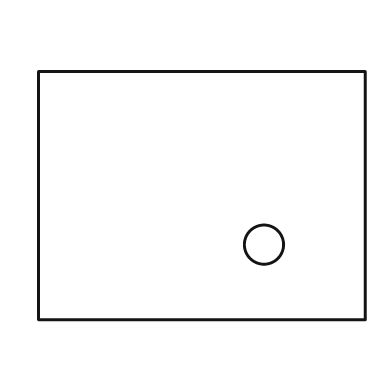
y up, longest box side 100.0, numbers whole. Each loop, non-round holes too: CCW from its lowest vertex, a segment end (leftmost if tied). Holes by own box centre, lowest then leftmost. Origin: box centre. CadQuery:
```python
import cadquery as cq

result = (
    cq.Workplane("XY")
    .moveTo(-50.0, -38.0)
    .lineTo(50.0, -38.0)
    .lineTo(50.0, 38.0)
    .lineTo(-50.0, 38.0)
    .close()
    .moveTo(19.0, -15.0)
    .circle(6.0)
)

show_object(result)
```